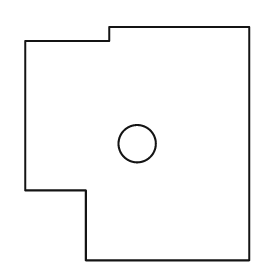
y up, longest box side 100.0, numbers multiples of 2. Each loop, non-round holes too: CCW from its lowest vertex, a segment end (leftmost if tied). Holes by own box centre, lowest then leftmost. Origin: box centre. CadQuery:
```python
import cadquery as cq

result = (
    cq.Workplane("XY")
    .moveTo(-22.0, -50.0)
    .lineTo(48.0, -50.0)
    .lineTo(48.0, 50.0)
    .lineTo(-12.0, 50.0)
    .lineTo(-12.0, 44.0)
    .lineTo(-48.0, 44.0)
    .lineTo(-48.0, -20.0)
    .lineTo(-22.0, -20.0)
    .close()
    .moveTo(0.0, 0.0)
    .circle(8.0)
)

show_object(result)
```